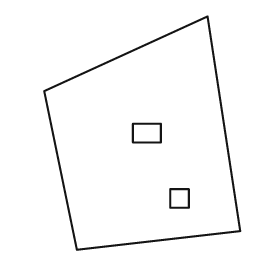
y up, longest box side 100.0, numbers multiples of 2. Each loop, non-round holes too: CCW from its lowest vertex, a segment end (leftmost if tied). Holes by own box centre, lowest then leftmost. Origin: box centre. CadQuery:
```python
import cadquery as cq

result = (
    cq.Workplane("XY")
    .moveTo(-28.0, -50.0)
    .lineTo(42.0, -42.0)
    .lineTo(28.0, 50.0)
    .lineTo(-42.0, 18.0)
    .close()
    .moveTo(12.0, -32.0)
    .lineTo(20.0, -32.0)
    .lineTo(20.0, -24.0)
    .lineTo(12.0, -24.0)
    .close()
    .moveTo(-4.0, -4.0)
    .lineTo(8.0, -4.0)
    .lineTo(8.0, 4.0)
    .lineTo(-4.0, 4.0)
    .close()
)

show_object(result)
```